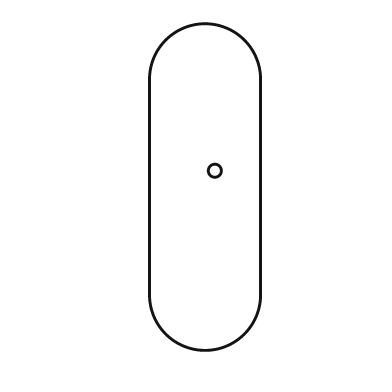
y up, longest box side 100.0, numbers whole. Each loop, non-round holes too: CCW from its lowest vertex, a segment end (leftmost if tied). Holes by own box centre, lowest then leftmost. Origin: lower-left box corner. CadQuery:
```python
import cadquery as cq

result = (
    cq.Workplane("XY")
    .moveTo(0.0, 17.0)
    .threePointArc((17.0, 0.0), (34.0, 17.0))
    .lineTo(34.0, 83.0)
    .threePointArc((17.0, 100.0), (0.0, 83.0))
    .close()
    .moveTo(20.0, 55.0)
    .circle(2.0)
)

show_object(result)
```